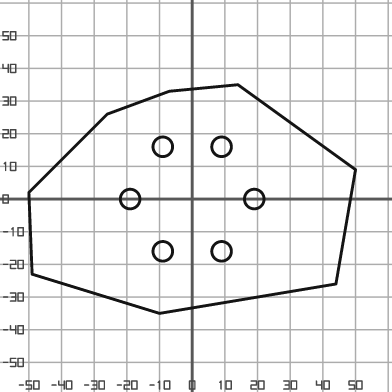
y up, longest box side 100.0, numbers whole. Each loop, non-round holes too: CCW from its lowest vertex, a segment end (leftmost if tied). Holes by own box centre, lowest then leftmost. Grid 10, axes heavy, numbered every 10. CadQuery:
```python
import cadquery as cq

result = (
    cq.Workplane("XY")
    .moveTo(-10.0, -35.0)
    .lineTo(44.0, -26.0)
    .lineTo(50.0, 9.0)
    .lineTo(14.0, 35.0)
    .lineTo(-7.0, 33.0)
    .lineTo(-26.0, 26.0)
    .lineTo(-50.0, 2.0)
    .lineTo(-49.0, -23.0)
    .close()
    .moveTo(-9.0, -16.0)
    .circle(3.0)
    .moveTo(9.0, -16.0)
    .circle(3.0)
    .moveTo(-19.0, 0.0)
    .circle(3.0)
    .moveTo(19.0, 0.0)
    .circle(3.0)
    .moveTo(-9.0, 16.0)
    .circle(3.0)
    .moveTo(9.0, 16.0)
    .circle(3.0)
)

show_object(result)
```